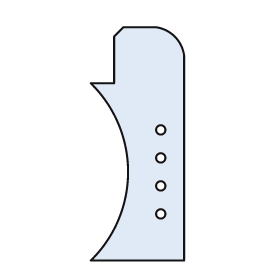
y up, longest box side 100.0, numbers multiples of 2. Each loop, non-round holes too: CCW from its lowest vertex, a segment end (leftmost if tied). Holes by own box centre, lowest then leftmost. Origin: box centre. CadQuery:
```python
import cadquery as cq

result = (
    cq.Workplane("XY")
    .moveTo(-20.0, -50.0)
    .lineTo(20.0, -50.0)
    .lineTo(20.0, 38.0)
    .threePointArc((16.0, 46.0), (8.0, 50.0))
    .lineTo(-6.0, 50.0)
    .lineTo(-10.0, 46.0)
    .lineTo(-10.0, 26.0)
    .lineTo(-20.0, 26.0)
    .threePointArc((-4.0, -12.0), (-20.0, -50.0))
    .close()
    .moveTo(10.0, -30.0)
    .circle(2.0)
    .moveTo(10.0, -18.0)
    .circle(2.0)
    .moveTo(10.0, -6.0)
    .circle(2.0)
    .moveTo(10.0, 6.0)
    .circle(2.0)
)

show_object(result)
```